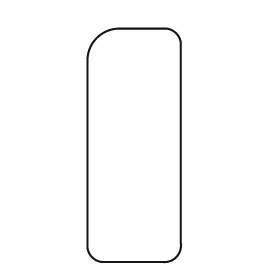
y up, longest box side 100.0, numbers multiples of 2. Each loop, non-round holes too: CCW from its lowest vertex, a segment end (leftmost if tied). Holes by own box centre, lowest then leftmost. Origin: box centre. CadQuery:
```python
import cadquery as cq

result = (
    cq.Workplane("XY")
    .moveTo(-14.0, -50.0)
    .lineTo(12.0, -50.0)
    .threePointArc((18.0, -48.0), (20.0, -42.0))
    .lineTo(20.0, 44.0)
    .threePointArc((18.0, 48.0), (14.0, 50.0))
    .lineTo(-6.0, 50.0)
    .threePointArc((-16.0, 46.0), (-20.0, 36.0))
    .lineTo(-20.0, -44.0)
    .threePointArc((-18.0, -48.0), (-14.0, -50.0))
    .close()
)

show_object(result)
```